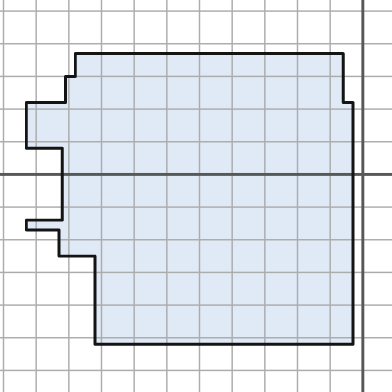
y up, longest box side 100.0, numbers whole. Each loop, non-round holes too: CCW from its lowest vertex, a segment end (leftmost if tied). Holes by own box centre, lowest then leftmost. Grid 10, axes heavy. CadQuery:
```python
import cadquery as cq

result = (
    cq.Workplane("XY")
    .moveTo(-82.0, -52.0)
    .lineTo(-3.0, -52.0)
    .lineTo(-3.0, 22.0)
    .lineTo(-6.0, 22.0)
    .lineTo(-6.0, 37.0)
    .lineTo(-88.0, 37.0)
    .lineTo(-88.0, 30.0)
    .lineTo(-91.0, 30.0)
    .lineTo(-91.0, 22.0)
    .lineTo(-103.0, 22.0)
    .lineTo(-103.0, 8.0)
    .lineTo(-92.0, 8.0)
    .lineTo(-92.0, -14.0)
    .lineTo(-103.0, -14.0)
    .lineTo(-103.0, -17.0)
    .lineTo(-93.0, -17.0)
    .lineTo(-93.0, -25.0)
    .lineTo(-82.0, -25.0)
    .close()
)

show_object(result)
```